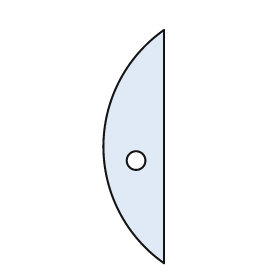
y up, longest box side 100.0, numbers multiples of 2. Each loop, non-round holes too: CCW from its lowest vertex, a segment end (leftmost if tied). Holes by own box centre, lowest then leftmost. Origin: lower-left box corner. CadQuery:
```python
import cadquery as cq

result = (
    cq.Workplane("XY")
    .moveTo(26.0, 0.0)
    .lineTo(26.0, 100.0)
    .threePointArc((0.0, 50.0), (26.0, 0.0))
    .close()
    .moveTo(14.0, 44.0)
    .circle(4.0)
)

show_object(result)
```